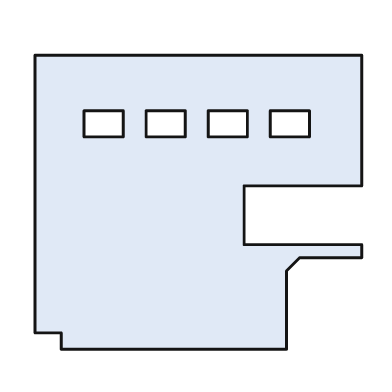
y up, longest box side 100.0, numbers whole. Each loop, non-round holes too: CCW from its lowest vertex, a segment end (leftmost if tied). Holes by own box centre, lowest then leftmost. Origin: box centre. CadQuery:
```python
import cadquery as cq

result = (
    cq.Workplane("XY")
    .moveTo(-42.0, -45.0)
    .lineTo(27.0, -45.0)
    .lineTo(27.0, -21.0)
    .lineTo(31.0, -17.0)
    .lineTo(50.0, -17.0)
    .lineTo(50.0, -13.0)
    .lineTo(14.0, -13.0)
    .lineTo(14.0, 5.0)
    .lineTo(50.0, 5.0)
    .lineTo(50.0, 45.0)
    .lineTo(-50.0, 45.0)
    .lineTo(-50.0, -40.0)
    .lineTo(-42.0, -40.0)
    .close()
    .moveTo(-35.0, 20.0)
    .lineTo(-23.0, 20.0)
    .lineTo(-23.0, 28.0)
    .lineTo(-35.0, 28.0)
    .close()
    .moveTo(-16.0, 20.0)
    .lineTo(-4.0, 20.0)
    .lineTo(-4.0, 28.0)
    .lineTo(-16.0, 28.0)
    .close()
    .moveTo(3.0, 20.0)
    .lineTo(15.0, 20.0)
    .lineTo(15.0, 28.0)
    .lineTo(3.0, 28.0)
    .close()
    .moveTo(22.0, 20.0)
    .lineTo(34.0, 20.0)
    .lineTo(34.0, 28.0)
    .lineTo(22.0, 28.0)
    .close()
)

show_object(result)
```